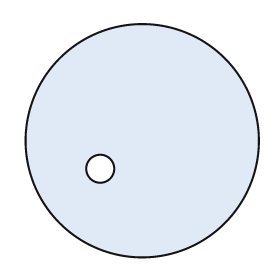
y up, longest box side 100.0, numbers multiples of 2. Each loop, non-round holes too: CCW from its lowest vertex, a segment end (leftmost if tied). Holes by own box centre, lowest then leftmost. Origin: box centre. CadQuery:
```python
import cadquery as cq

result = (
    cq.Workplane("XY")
    .moveTo(0.0, 0.0)
    .circle(50.0)
    .moveTo(-18.0, -12.0)
    .circle(6.0)
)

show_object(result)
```